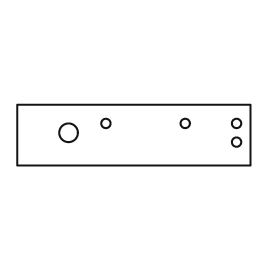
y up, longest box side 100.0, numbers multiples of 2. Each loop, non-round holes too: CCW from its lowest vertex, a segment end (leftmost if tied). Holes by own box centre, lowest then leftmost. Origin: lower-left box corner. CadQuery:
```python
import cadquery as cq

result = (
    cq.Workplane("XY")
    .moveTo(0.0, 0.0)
    .lineTo(100.0, 0.0)
    .lineTo(100.0, 26.0)
    .lineTo(0.0, 26.0)
    .close()
    .moveTo(94.0, 10.0)
    .circle(2.0)
    .moveTo(22.0, 14.0)
    .circle(4.0)
    .moveTo(38.0, 18.0)
    .circle(2.0)
    .moveTo(72.0, 18.0)
    .circle(2.0)
    .moveTo(94.0, 18.0)
    .circle(2.0)
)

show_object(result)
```